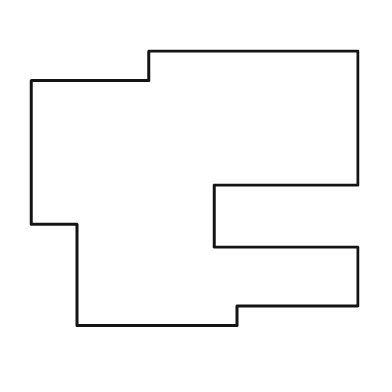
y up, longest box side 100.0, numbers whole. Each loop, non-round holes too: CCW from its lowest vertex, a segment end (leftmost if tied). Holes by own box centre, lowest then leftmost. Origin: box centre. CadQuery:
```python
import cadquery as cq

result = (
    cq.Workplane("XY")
    .moveTo(-36.0, -42.0)
    .lineTo(13.0, -42.0)
    .lineTo(13.0, -36.0)
    .lineTo(50.0, -36.0)
    .lineTo(50.0, -18.0)
    .lineTo(6.0, -18.0)
    .lineTo(6.0, 1.0)
    .lineTo(50.0, 1.0)
    .lineTo(50.0, 42.0)
    .lineTo(-14.0, 42.0)
    .lineTo(-14.0, 33.0)
    .lineTo(-50.0, 33.0)
    .lineTo(-50.0, -11.0)
    .lineTo(-36.0, -11.0)
    .close()
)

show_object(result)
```